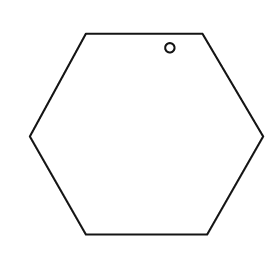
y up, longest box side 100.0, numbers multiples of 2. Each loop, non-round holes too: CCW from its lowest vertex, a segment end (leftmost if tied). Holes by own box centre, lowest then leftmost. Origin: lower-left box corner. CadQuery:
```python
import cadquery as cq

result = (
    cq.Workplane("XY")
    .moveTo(24.0, 0.0)
    .lineTo(76.0, 0.0)
    .lineTo(100.0, 42.0)
    .lineTo(74.0, 86.0)
    .lineTo(24.0, 86.0)
    .lineTo(0.0, 42.0)
    .close()
    .moveTo(60.0, 80.0)
    .circle(2.0)
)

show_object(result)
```